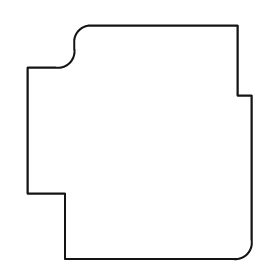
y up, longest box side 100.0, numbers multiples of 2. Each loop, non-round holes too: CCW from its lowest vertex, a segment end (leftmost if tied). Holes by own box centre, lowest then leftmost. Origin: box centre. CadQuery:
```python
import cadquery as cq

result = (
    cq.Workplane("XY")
    .moveTo(-32.0, -50.0)
    .lineTo(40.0, -50.0)
    .threePointArc((46.0, -48.0), (48.0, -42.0))
    .lineTo(48.0, 20.0)
    .lineTo(42.0, 20.0)
    .lineTo(42.0, 50.0)
    .lineTo(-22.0, 50.0)
    .threePointArc((-26.0, 48.0), (-28.0, 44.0))
    .lineTo(-28.0, 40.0)
    .threePointArc((-30.0, 34.0), (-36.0, 32.0))
    .lineTo(-48.0, 32.0)
    .lineTo(-48.0, -22.0)
    .lineTo(-32.0, -22.0)
    .close()
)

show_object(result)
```